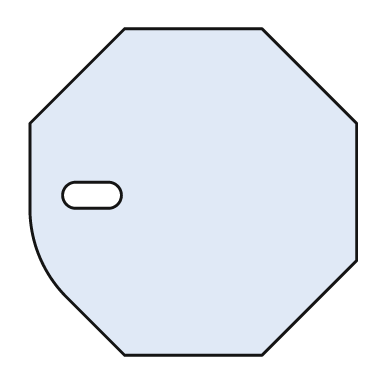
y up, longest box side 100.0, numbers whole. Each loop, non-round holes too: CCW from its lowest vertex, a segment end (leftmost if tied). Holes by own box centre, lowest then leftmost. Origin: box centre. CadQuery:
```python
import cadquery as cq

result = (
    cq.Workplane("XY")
    .moveTo(-21.0, -50.0)
    .lineTo(21.0, -50.0)
    .lineTo(50.0, -21.0)
    .lineTo(50.0, 21.0)
    .lineTo(21.0, 50.0)
    .lineTo(-21.0, 50.0)
    .lineTo(-50.0, 21.0)
    .lineTo(-50.0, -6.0)
    .threePointArc((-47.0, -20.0), (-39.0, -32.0))
    .close()
    .moveTo(-36.0, -5.0)
    .lineTo(-26.0, -5.0)
    .threePointArc((-22.0, -1.0), (-26.0, 3.0))
    .lineTo(-36.0, 3.0)
    .threePointArc((-40.0, -1.0), (-36.0, -5.0))
    .close()
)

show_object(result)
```